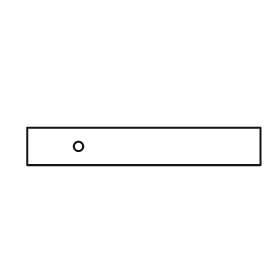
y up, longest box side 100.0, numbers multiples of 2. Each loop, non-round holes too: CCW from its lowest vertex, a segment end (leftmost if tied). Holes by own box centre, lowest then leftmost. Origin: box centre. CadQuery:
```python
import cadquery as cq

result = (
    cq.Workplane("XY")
    .moveTo(-50.0, -8.0)
    .lineTo(50.0, -8.0)
    .lineTo(50.0, 8.0)
    .lineTo(-50.0, 8.0)
    .close()
    .moveTo(-28.0, 0.0)
    .circle(2.0)
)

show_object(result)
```